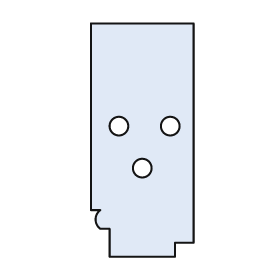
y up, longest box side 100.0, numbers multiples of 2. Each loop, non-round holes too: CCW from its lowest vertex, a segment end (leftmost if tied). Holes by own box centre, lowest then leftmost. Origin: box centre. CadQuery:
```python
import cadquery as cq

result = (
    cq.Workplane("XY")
    .moveTo(-14.0, -50.0)
    .lineTo(14.0, -50.0)
    .lineTo(14.0, -44.0)
    .lineTo(22.0, -44.0)
    .lineTo(22.0, 50.0)
    .lineTo(-22.0, 50.0)
    .lineTo(-22.0, -30.0)
    .lineTo(-18.0, -30.0)
    .threePointArc((-20.0, -34.0), (-18.0, -38.0))
    .lineTo(-14.0, -38.0)
    .close()
    .moveTo(0.0, -12.0)
    .circle(4.0)
    .moveTo(-10.0, 6.0)
    .circle(4.0)
    .moveTo(12.0, 6.0)
    .circle(4.0)
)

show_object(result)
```